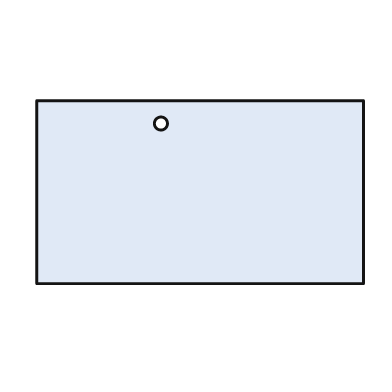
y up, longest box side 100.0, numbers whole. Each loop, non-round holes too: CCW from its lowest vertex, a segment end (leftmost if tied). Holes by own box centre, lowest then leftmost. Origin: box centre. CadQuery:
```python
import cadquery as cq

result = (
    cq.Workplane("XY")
    .moveTo(-50.0, -28.0)
    .lineTo(50.0, -28.0)
    .lineTo(50.0, 28.0)
    .lineTo(-50.0, 28.0)
    .close()
    .moveTo(-12.0, 21.0)
    .circle(2.0)
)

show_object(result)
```